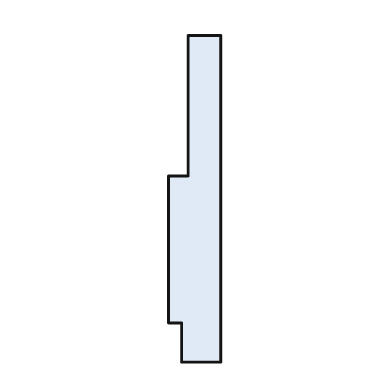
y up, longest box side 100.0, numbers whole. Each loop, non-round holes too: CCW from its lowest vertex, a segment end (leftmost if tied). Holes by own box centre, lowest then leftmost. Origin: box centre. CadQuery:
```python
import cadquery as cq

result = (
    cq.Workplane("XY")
    .moveTo(-4.0, -50.0)
    .lineTo(8.0, -50.0)
    .lineTo(8.0, 50.0)
    .lineTo(-2.0, 50.0)
    .lineTo(-2.0, 7.0)
    .lineTo(-8.0, 7.0)
    .lineTo(-8.0, -38.0)
    .lineTo(-4.0, -38.0)
    .close()
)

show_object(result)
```